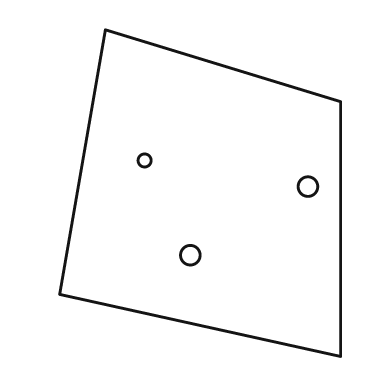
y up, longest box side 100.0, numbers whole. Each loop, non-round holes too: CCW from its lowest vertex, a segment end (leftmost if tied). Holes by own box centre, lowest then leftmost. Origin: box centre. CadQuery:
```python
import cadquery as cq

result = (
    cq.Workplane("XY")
    .moveTo(43.0, -50.0)
    .lineTo(43.0, 28.0)
    .lineTo(-29.0, 50.0)
    .lineTo(-43.0, -31.0)
    .close()
    .moveTo(-3.0, -19.0)
    .circle(3.0)
    .moveTo(33.0, 2.0)
    .circle(3.0)
    .moveTo(-17.0, 10.0)
    .circle(2.0)
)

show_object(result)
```